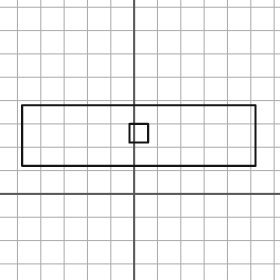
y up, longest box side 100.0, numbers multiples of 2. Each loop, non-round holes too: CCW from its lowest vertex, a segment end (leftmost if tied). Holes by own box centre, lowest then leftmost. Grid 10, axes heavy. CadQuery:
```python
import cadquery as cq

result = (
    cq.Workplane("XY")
    .moveTo(-48.0, 12.0)
    .lineTo(52.0, 12.0)
    .lineTo(52.0, 38.0)
    .lineTo(-48.0, 38.0)
    .close()
    .moveTo(-2.0, 22.0)
    .lineTo(6.0, 22.0)
    .lineTo(6.0, 30.0)
    .lineTo(-2.0, 30.0)
    .close()
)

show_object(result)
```